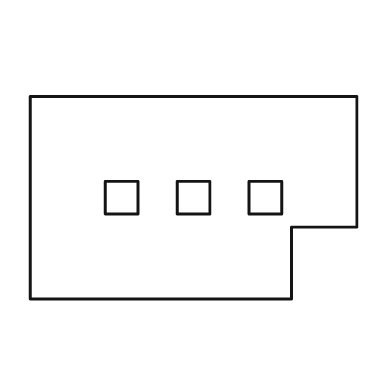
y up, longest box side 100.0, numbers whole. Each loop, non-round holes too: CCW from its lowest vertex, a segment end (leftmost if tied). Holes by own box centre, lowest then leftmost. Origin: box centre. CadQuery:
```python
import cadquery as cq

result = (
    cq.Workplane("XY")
    .moveTo(-50.0, -31.0)
    .lineTo(30.0, -31.0)
    .lineTo(30.0, -9.0)
    .lineTo(50.0, -9.0)
    .lineTo(50.0, 31.0)
    .lineTo(-50.0, 31.0)
    .close()
    .moveTo(-27.0, -5.0)
    .lineTo(-17.0, -5.0)
    .lineTo(-17.0, 5.0)
    .lineTo(-27.0, 5.0)
    .close()
    .moveTo(-5.0, -5.0)
    .lineTo(5.0, -5.0)
    .lineTo(5.0, 5.0)
    .lineTo(-5.0, 5.0)
    .close()
    .moveTo(17.0, -5.0)
    .lineTo(27.0, -5.0)
    .lineTo(27.0, 5.0)
    .lineTo(17.0, 5.0)
    .close()
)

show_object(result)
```